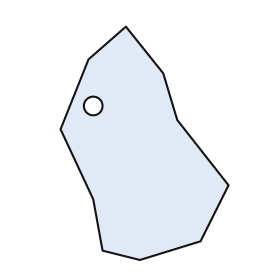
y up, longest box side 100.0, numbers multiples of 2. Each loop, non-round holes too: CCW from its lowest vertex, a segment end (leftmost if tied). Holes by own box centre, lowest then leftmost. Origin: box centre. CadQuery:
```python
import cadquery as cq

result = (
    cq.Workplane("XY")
    .moveTo(-2.0, -50.0)
    .lineTo(24.0, -42.0)
    .lineTo(36.0, -18.0)
    .lineTo(14.0, 10.0)
    .lineTo(8.0, 30.0)
    .lineTo(-8.0, 50.0)
    .lineTo(-24.0, 36.0)
    .lineTo(-36.0, 6.0)
    .lineTo(-22.0, -24.0)
    .lineTo(-18.0, -46.0)
    .close()
    .moveTo(-22.0, 16.0)
    .circle(4.0)
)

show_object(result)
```